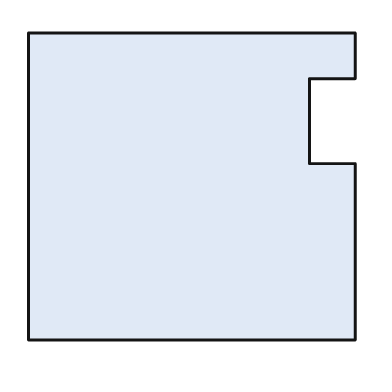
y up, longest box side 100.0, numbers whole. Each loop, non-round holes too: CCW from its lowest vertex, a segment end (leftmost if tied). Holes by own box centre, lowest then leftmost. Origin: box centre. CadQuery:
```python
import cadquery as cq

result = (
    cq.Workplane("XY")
    .moveTo(-50.0, -47.0)
    .lineTo(50.0, -47.0)
    .lineTo(50.0, 7.0)
    .lineTo(36.0, 7.0)
    .lineTo(36.0, 33.0)
    .lineTo(50.0, 33.0)
    .lineTo(50.0, 47.0)
    .lineTo(-50.0, 47.0)
    .close()
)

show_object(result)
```